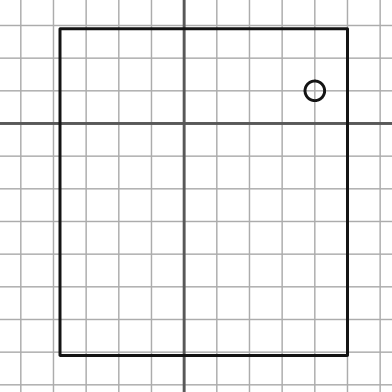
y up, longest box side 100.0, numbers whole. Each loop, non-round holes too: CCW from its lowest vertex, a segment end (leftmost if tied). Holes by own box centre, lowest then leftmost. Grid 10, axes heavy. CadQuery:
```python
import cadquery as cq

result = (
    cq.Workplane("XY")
    .moveTo(-38.0, -71.0)
    .lineTo(50.0, -71.0)
    .lineTo(50.0, 29.0)
    .lineTo(-38.0, 29.0)
    .close()
    .moveTo(40.0, 10.0)
    .circle(3.0)
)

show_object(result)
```